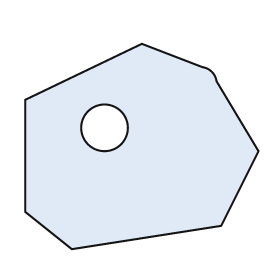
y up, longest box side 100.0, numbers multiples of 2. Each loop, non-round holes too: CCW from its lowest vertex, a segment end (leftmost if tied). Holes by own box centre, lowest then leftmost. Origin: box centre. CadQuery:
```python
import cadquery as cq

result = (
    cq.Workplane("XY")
    .moveTo(-30.0, -44.0)
    .lineTo(34.0, -34.0)
    .lineTo(50.0, -2.0)
    .lineTo(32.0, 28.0)
    .threePointArc((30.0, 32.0), (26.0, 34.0))
    .lineTo(0.0, 44.0)
    .lineTo(-50.0, 20.0)
    .lineTo(-50.0, -28.0)
    .close()
    .moveTo(-16.0, 8.0)
    .circle(10.0)
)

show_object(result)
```